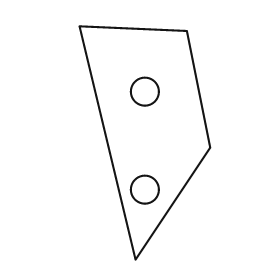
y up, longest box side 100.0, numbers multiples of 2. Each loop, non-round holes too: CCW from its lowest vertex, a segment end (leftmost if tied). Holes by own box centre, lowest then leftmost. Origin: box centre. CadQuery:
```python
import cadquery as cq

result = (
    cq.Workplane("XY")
    .moveTo(-4.0, -50.0)
    .lineTo(28.0, -2.0)
    .lineTo(18.0, 48.0)
    .lineTo(-28.0, 50.0)
    .close()
    .moveTo(0.0, -20.0)
    .circle(6.0)
    .moveTo(0.0, 22.0)
    .circle(6.0)
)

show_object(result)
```